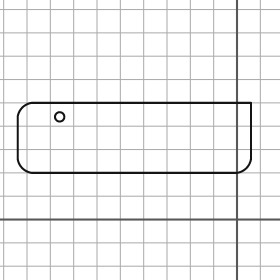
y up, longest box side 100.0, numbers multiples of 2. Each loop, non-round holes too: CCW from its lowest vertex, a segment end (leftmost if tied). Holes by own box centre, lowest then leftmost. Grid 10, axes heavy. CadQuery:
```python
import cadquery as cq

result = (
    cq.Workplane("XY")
    .moveTo(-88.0, 20.0)
    .lineTo(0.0, 20.0)
    .threePointArc((4.0, 22.0), (6.0, 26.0))
    .lineTo(6.0, 50.0)
    .lineTo(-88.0, 50.0)
    .threePointArc((-92.0, 48.0), (-94.0, 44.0))
    .lineTo(-94.0, 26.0)
    .threePointArc((-92.0, 22.0), (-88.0, 20.0))
    .close()
    .moveTo(-76.0, 44.0)
    .circle(2.0)
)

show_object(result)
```